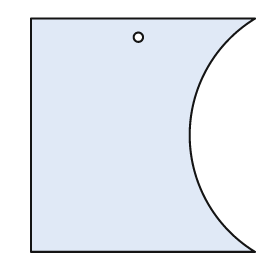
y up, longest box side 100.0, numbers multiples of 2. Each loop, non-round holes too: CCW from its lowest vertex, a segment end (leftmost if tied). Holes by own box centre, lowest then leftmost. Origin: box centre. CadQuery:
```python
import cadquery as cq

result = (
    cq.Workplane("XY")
    .moveTo(-48.0, -50.0)
    .lineTo(48.0, -50.0)
    .threePointArc((20.0, 0.0), (48.0, 50.0))
    .lineTo(-48.0, 50.0)
    .close()
    .moveTo(-2.0, 42.0)
    .circle(2.0)
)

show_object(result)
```